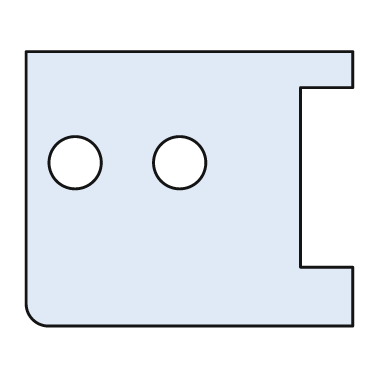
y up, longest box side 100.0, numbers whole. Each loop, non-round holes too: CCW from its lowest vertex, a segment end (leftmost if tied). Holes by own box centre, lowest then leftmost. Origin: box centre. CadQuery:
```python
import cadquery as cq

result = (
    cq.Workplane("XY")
    .moveTo(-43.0, -42.0)
    .lineTo(50.0, -42.0)
    .lineTo(50.0, -24.0)
    .lineTo(34.0, -24.0)
    .lineTo(34.0, 31.0)
    .lineTo(50.0, 31.0)
    .lineTo(50.0, 42.0)
    .lineTo(-50.0, 42.0)
    .lineTo(-50.0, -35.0)
    .threePointArc((-48.0, -40.0), (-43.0, -42.0))
    .close()
    .moveTo(-35.0, 8.0)
    .circle(8.0)
    .moveTo(-3.0, 8.0)
    .circle(8.0)
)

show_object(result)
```